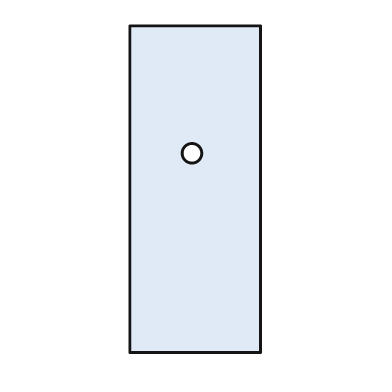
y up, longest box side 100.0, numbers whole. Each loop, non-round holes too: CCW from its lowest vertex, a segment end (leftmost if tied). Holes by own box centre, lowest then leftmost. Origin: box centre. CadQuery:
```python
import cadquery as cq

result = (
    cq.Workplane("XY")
    .moveTo(-20.0, -50.0)
    .lineTo(20.0, -50.0)
    .lineTo(20.0, 50.0)
    .lineTo(-20.0, 50.0)
    .close()
    .moveTo(-1.0, 11.0)
    .circle(3.0)
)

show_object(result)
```